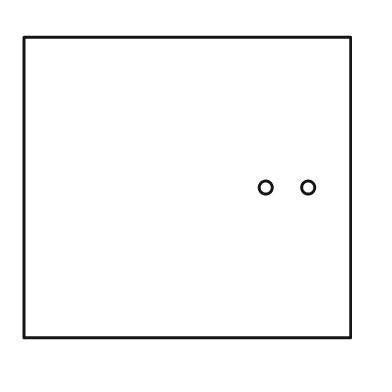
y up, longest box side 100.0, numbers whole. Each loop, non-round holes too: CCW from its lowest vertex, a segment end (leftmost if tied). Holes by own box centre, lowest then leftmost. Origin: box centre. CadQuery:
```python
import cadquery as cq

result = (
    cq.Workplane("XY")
    .moveTo(-50.0, -46.0)
    .lineTo(50.0, -46.0)
    .lineTo(50.0, 46.0)
    .lineTo(-50.0, 46.0)
    .close()
    .moveTo(24.0, 0.0)
    .circle(2.0)
    .moveTo(37.0, 0.0)
    .circle(2.0)
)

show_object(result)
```